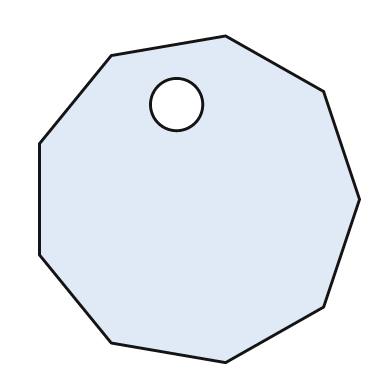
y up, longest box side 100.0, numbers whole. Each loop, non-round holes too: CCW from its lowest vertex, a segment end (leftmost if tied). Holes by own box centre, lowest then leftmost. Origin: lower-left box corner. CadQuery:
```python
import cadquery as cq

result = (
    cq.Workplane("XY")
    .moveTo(57.0, 0.0)
    .lineTo(87.0, 17.0)
    .lineTo(98.0, 50.0)
    .lineTo(87.0, 83.0)
    .lineTo(57.0, 100.0)
    .lineTo(22.0, 94.0)
    .lineTo(0.0, 67.0)
    .lineTo(0.0, 33.0)
    .lineTo(22.0, 6.0)
    .close()
    .moveTo(42.0, 79.0)
    .circle(8.0)
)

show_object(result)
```